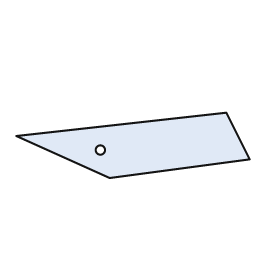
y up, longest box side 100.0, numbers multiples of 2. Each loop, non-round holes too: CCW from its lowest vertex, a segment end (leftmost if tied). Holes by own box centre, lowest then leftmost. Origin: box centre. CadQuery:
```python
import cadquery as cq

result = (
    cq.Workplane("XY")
    .moveTo(-10.0, -14.0)
    .lineTo(50.0, -6.0)
    .lineTo(40.0, 14.0)
    .lineTo(-50.0, 4.0)
    .close()
    .moveTo(-14.0, -2.0)
    .circle(2.0)
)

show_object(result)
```